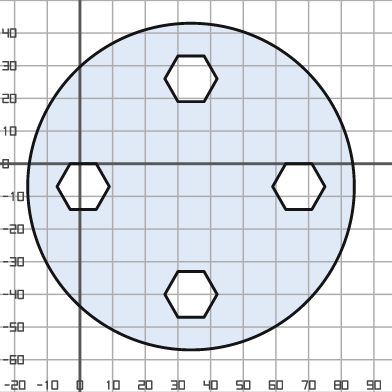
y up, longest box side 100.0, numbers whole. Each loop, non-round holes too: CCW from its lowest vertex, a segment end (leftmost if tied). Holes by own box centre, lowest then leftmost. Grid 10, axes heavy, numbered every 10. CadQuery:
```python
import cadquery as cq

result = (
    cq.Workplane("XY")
    .moveTo(34.0, -7.0)
    .circle(50.0)
    .moveTo(30.0, -47.0)
    .lineTo(38.0, -47.0)
    .lineTo(42.0, -40.0)
    .lineTo(38.0, -33.0)
    .lineTo(30.0, -33.0)
    .lineTo(26.0, -40.0)
    .close()
    .moveTo(-3.0, -14.0)
    .lineTo(5.0, -14.0)
    .lineTo(9.0, -7.0)
    .lineTo(5.0, 0.0)
    .lineTo(-3.0, 0.0)
    .lineTo(-7.0, -7.0)
    .close()
    .moveTo(63.0, -14.0)
    .lineTo(71.0, -14.0)
    .lineTo(75.0, -7.0)
    .lineTo(71.0, 0.0)
    .lineTo(63.0, 0.0)
    .lineTo(59.0, -7.0)
    .close()
    .moveTo(30.0, 19.0)
    .lineTo(38.0, 19.0)
    .lineTo(42.0, 26.0)
    .lineTo(38.0, 33.0)
    .lineTo(30.0, 33.0)
    .lineTo(26.0, 26.0)
    .close()
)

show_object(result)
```